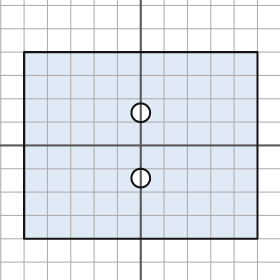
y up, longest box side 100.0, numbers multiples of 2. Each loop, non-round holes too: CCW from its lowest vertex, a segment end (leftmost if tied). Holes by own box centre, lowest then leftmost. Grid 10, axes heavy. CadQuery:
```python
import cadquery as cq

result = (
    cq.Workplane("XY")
    .moveTo(-50.0, -40.0)
    .lineTo(50.0, -40.0)
    .lineTo(50.0, 40.0)
    .lineTo(-50.0, 40.0)
    .close()
    .moveTo(0.0, -14.0)
    .circle(4.0)
    .moveTo(0.0, 14.0)
    .circle(4.0)
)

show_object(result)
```